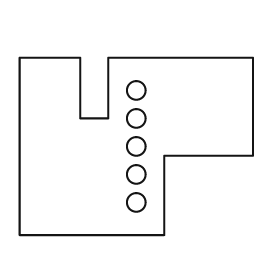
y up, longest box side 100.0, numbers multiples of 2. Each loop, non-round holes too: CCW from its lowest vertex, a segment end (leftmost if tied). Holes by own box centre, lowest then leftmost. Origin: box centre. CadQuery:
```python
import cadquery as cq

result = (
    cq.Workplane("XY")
    .moveTo(-50.0, -38.0)
    .lineTo(12.0, -38.0)
    .lineTo(12.0, -4.0)
    .lineTo(50.0, -4.0)
    .lineTo(50.0, 38.0)
    .lineTo(-12.0, 38.0)
    .lineTo(-12.0, 12.0)
    .lineTo(-24.0, 12.0)
    .lineTo(-24.0, 38.0)
    .lineTo(-50.0, 38.0)
    .close()
    .moveTo(0.0, -24.0)
    .circle(4.0)
    .moveTo(0.0, -12.0)
    .circle(4.0)
    .moveTo(0.0, 0.0)
    .circle(4.0)
    .moveTo(0.0, 12.0)
    .circle(4.0)
    .moveTo(0.0, 24.0)
    .circle(4.0)
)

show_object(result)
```